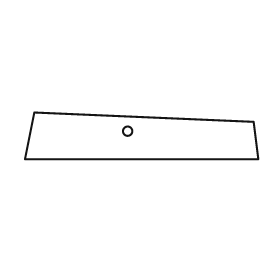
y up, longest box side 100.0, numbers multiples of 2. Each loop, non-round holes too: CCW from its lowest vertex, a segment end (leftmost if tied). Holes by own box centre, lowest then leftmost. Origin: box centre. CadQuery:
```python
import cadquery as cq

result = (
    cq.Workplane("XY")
    .moveTo(-50.0, -10.0)
    .lineTo(50.0, -10.0)
    .lineTo(48.0, 6.0)
    .lineTo(-46.0, 10.0)
    .close()
    .moveTo(-6.0, 2.0)
    .circle(2.0)
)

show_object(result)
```